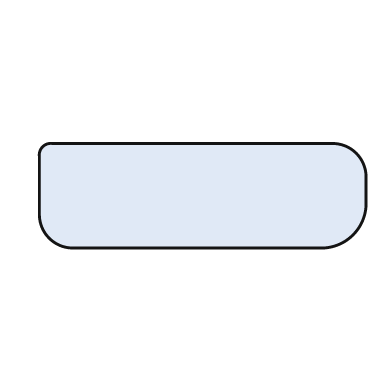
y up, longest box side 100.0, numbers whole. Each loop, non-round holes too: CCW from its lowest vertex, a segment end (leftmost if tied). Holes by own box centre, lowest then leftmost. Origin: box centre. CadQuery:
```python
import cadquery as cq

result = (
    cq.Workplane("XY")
    .moveTo(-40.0, -16.0)
    .lineTo(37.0, -16.0)
    .threePointArc((46.0, -12.0), (50.0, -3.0))
    .lineTo(50.0, 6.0)
    .threePointArc((47.0, 13.0), (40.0, 16.0))
    .lineTo(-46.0, 16.0)
    .threePointArc((-49.0, 15.0), (-50.0, 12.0))
    .lineTo(-50.0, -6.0)
    .threePointArc((-47.0, -13.0), (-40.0, -16.0))
    .close()
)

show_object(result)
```